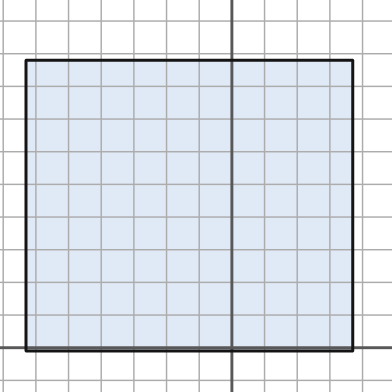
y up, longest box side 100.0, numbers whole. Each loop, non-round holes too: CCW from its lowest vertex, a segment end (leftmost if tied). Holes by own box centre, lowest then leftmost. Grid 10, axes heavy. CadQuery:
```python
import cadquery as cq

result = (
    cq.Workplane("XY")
    .moveTo(-63.0, -1.0)
    .lineTo(37.0, -1.0)
    .lineTo(37.0, 88.0)
    .lineTo(-63.0, 88.0)
    .close()
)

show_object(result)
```